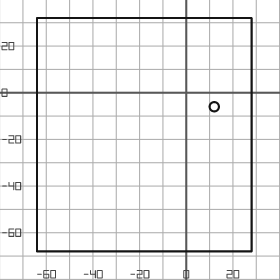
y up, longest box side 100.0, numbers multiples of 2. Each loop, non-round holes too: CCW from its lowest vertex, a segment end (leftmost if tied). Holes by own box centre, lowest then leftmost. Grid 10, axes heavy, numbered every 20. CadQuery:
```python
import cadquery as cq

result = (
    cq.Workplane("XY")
    .moveTo(-64.0, -68.0)
    .lineTo(28.0, -68.0)
    .lineTo(28.0, 32.0)
    .lineTo(-64.0, 32.0)
    .close()
    .moveTo(12.0, -6.0)
    .circle(2.0)
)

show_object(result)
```